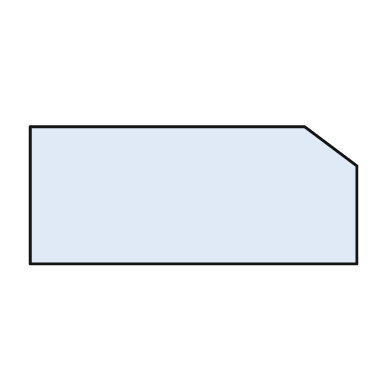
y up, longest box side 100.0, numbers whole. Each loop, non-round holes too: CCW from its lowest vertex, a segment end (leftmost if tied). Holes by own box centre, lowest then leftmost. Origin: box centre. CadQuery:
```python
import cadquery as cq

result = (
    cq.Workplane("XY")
    .moveTo(-50.0, -21.0)
    .lineTo(50.0, -21.0)
    .lineTo(50.0, 9.0)
    .lineTo(34.0, 21.0)
    .lineTo(-50.0, 21.0)
    .close()
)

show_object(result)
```